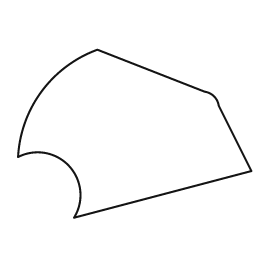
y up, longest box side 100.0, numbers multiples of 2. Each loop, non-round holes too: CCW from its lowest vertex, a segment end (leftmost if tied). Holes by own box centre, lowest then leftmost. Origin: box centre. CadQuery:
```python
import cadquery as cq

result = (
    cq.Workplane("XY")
    .moveTo(-26.0, -36.0)
    .lineTo(50.0, -16.0)
    .lineTo(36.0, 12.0)
    .threePointArc((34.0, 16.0), (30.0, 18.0))
    .lineTo(-16.0, 36.0)
    .threePointArc((-40.0, 18.0), (-50.0, -10.0))
    .threePointArc((-28.0, -14.0), (-26.0, -36.0))
    .close()
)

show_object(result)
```